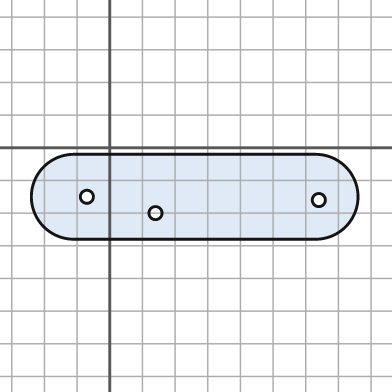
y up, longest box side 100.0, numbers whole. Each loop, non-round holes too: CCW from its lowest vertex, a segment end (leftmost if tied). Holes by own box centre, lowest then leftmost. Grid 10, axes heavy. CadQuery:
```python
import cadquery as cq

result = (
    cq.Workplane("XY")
    .moveTo(-11.0, -28.0)
    .lineTo(63.0, -28.0)
    .threePointArc((76.0, -15.0), (63.0, -2.0))
    .lineTo(-11.0, -2.0)
    .threePointArc((-24.0, -15.0), (-11.0, -28.0))
    .close()
    .moveTo(14.0, -20.0)
    .circle(2.0)
    .moveTo(64.0, -16.0)
    .circle(2.0)
    .moveTo(-7.0, -15.0)
    .circle(2.0)
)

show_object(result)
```